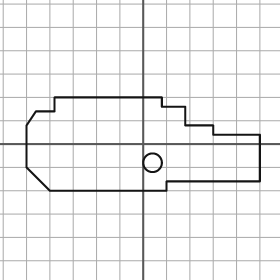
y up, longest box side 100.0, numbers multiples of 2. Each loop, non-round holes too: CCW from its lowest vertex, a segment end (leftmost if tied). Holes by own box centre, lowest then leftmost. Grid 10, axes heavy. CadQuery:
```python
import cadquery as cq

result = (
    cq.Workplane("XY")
    .moveTo(-40.0, -20.0)
    .lineTo(10.0, -20.0)
    .lineTo(10.0, -16.0)
    .lineTo(50.0, -16.0)
    .lineTo(50.0, 4.0)
    .lineTo(30.0, 4.0)
    .lineTo(30.0, 8.0)
    .lineTo(18.0, 8.0)
    .lineTo(18.0, 16.0)
    .lineTo(8.0, 16.0)
    .lineTo(8.0, 20.0)
    .lineTo(-38.0, 20.0)
    .lineTo(-38.0, 14.0)
    .lineTo(-46.0, 14.0)
    .lineTo(-50.0, 8.0)
    .lineTo(-50.0, -10.0)
    .close()
    .moveTo(4.0, -8.0)
    .circle(4.0)
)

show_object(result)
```